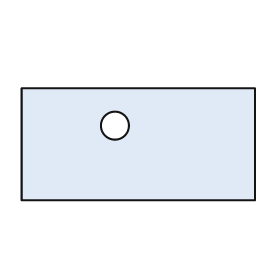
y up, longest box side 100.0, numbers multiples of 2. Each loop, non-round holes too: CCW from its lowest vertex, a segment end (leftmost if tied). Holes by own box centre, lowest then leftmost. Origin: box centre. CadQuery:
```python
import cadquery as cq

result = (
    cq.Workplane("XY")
    .moveTo(-50.0, -24.0)
    .lineTo(50.0, -24.0)
    .lineTo(50.0, 24.0)
    .lineTo(-50.0, 24.0)
    .close()
    .moveTo(-10.0, 8.0)
    .circle(6.0)
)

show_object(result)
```